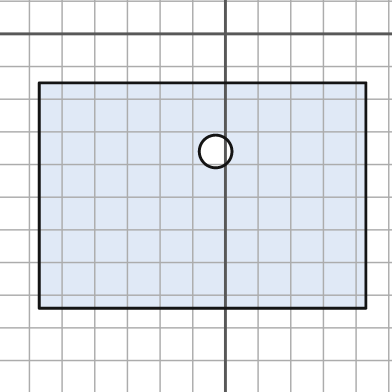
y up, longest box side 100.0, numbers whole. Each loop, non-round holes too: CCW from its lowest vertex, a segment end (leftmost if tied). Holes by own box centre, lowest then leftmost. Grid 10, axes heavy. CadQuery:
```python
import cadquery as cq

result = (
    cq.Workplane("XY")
    .moveTo(-57.0, -84.0)
    .lineTo(43.0, -84.0)
    .lineTo(43.0, -15.0)
    .lineTo(-57.0, -15.0)
    .close()
    .moveTo(-3.0, -36.0)
    .circle(5.0)
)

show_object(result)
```